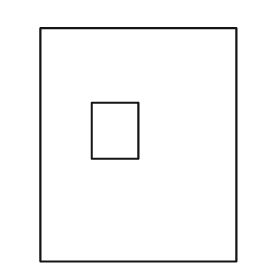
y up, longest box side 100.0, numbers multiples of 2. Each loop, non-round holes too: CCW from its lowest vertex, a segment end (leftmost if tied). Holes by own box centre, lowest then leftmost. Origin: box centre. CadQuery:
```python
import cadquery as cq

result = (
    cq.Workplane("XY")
    .moveTo(-42.0, -50.0)
    .lineTo(42.0, -50.0)
    .lineTo(42.0, 50.0)
    .lineTo(-42.0, 50.0)
    .close()
    .moveTo(-20.0, -6.0)
    .lineTo(0.0, -6.0)
    .lineTo(0.0, 18.0)
    .lineTo(-20.0, 18.0)
    .close()
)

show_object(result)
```